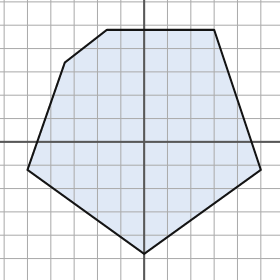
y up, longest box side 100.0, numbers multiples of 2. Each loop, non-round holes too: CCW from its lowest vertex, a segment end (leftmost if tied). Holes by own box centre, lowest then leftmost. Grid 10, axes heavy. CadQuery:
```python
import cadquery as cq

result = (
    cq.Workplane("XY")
    .moveTo(0.0, -48.0)
    .lineTo(50.0, -12.0)
    .lineTo(30.0, 48.0)
    .lineTo(-16.0, 48.0)
    .lineTo(-34.0, 34.0)
    .lineTo(-50.0, -12.0)
    .close()
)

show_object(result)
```